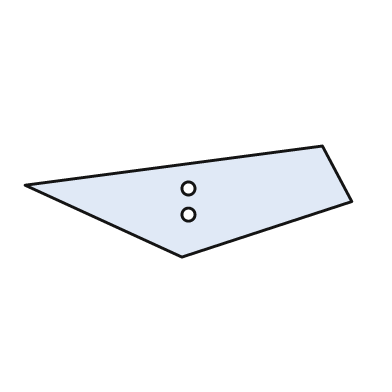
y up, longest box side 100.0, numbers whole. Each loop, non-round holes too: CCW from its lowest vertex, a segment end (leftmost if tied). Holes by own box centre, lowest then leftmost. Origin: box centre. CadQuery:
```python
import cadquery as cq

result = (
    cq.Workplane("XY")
    .moveTo(-2.0, -17.0)
    .lineTo(50.0, 0.0)
    .lineTo(41.0, 17.0)
    .lineTo(-50.0, 5.0)
    .close()
    .moveTo(0.0, -4.0)
    .circle(2.0)
    .moveTo(0.0, 4.0)
    .circle(2.0)
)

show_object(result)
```